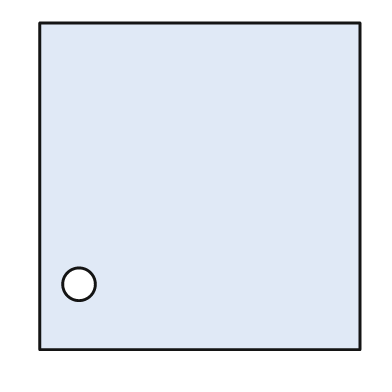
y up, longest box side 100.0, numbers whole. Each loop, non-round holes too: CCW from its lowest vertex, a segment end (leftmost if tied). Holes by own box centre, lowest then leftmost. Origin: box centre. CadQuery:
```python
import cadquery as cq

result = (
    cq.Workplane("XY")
    .moveTo(-49.0, -50.0)
    .lineTo(49.0, -50.0)
    .lineTo(49.0, 50.0)
    .lineTo(-49.0, 50.0)
    .close()
    .moveTo(-37.0, -30.0)
    .circle(5.0)
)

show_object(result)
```